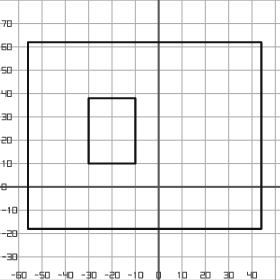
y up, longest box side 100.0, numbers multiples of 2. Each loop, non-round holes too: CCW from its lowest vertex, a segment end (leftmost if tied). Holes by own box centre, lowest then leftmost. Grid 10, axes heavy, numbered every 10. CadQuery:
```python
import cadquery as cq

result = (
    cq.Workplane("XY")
    .moveTo(-56.0, -18.0)
    .lineTo(44.0, -18.0)
    .lineTo(44.0, 62.0)
    .lineTo(-56.0, 62.0)
    .close()
    .moveTo(-30.0, 10.0)
    .lineTo(-10.0, 10.0)
    .lineTo(-10.0, 38.0)
    .lineTo(-30.0, 38.0)
    .close()
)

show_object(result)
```